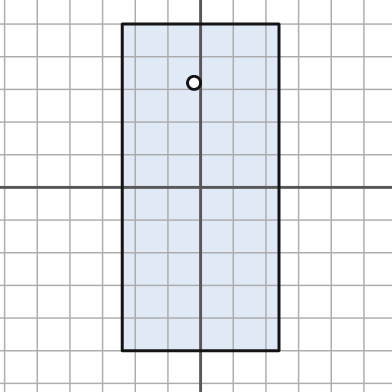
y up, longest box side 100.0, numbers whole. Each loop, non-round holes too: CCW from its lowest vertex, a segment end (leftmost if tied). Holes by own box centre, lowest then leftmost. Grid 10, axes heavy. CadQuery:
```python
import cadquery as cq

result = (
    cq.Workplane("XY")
    .moveTo(-24.0, -50.0)
    .lineTo(24.0, -50.0)
    .lineTo(24.0, 50.0)
    .lineTo(-24.0, 50.0)
    .close()
    .moveTo(-2.0, 32.0)
    .circle(2.0)
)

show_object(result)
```